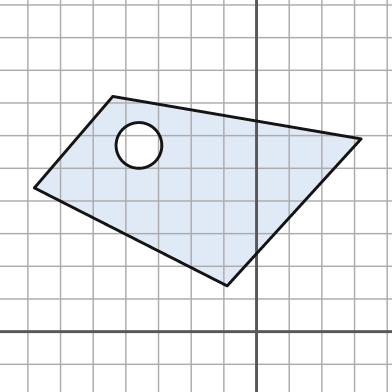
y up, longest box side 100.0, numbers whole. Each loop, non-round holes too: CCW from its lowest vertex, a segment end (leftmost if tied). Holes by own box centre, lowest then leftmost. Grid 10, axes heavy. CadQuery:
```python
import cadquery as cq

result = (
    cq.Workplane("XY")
    .moveTo(-9.0, 14.0)
    .lineTo(32.0, 59.0)
    .lineTo(-44.0, 72.0)
    .lineTo(-68.0, 44.0)
    .close()
    .moveTo(-36.0, 57.0)
    .circle(7.0)
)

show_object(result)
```